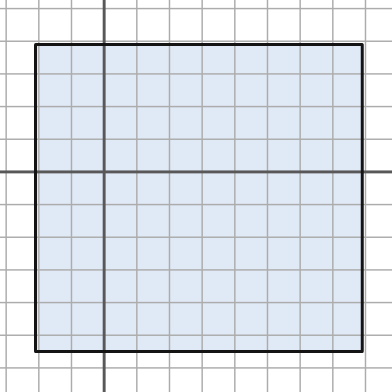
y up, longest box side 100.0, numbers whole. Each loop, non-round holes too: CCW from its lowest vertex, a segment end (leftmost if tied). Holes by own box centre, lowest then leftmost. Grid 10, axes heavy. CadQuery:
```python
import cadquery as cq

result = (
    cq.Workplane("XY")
    .moveTo(-21.0, -55.0)
    .lineTo(79.0, -55.0)
    .lineTo(79.0, 39.0)
    .lineTo(-21.0, 39.0)
    .close()
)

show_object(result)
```